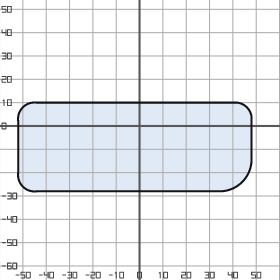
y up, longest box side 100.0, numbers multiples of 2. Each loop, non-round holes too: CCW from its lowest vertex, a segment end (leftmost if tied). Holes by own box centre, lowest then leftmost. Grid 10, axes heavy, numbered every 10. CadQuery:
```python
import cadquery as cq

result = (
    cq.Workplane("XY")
    .moveTo(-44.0, -28.0)
    .lineTo(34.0, -28.0)
    .threePointArc((44.0, -24.0), (48.0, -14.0))
    .lineTo(48.0, 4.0)
    .threePointArc((46.0, 8.0), (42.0, 10.0))
    .lineTo(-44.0, 10.0)
    .threePointArc((-50.0, 8.0), (-52.0, 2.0))
    .lineTo(-52.0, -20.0)
    .threePointArc((-50.0, -26.0), (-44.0, -28.0))
    .close()
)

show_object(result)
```